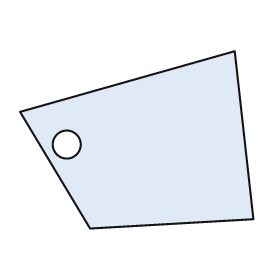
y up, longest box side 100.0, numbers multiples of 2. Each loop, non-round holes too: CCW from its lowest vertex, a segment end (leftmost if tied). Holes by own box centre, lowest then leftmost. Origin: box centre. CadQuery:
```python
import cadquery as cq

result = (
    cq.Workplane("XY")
    .moveTo(-20.0, -38.0)
    .lineTo(50.0, -34.0)
    .lineTo(42.0, 38.0)
    .lineTo(-50.0, 12.0)
    .close()
    .moveTo(-30.0, -2.0)
    .circle(6.0)
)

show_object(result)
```